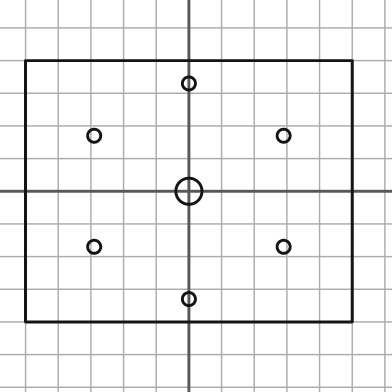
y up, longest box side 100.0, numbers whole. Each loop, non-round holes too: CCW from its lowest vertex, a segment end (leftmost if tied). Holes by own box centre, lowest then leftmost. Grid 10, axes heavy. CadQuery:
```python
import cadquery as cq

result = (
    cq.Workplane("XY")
    .moveTo(-50.0, -40.0)
    .lineTo(50.0, -40.0)
    .lineTo(50.0, 40.0)
    .lineTo(-50.0, 40.0)
    .close()
    .moveTo(0.0, -33.0)
    .circle(2.0)
    .moveTo(-29.0, -17.0)
    .circle(2.0)
    .moveTo(29.0, -17.0)
    .circle(2.0)
    .moveTo(0.0, 0.0)
    .circle(4.0)
    .moveTo(-29.0, 17.0)
    .circle(2.0)
    .moveTo(29.0, 17.0)
    .circle(2.0)
    .moveTo(0.0, 33.0)
    .circle(2.0)
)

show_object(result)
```